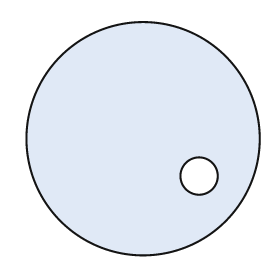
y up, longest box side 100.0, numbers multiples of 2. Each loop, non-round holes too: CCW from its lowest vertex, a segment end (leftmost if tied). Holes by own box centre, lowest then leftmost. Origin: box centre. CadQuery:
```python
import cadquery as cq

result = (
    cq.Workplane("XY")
    .moveTo(0.0, 0.0)
    .circle(50.0)
    .moveTo(24.0, -16.0)
    .circle(8.0)
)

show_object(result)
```